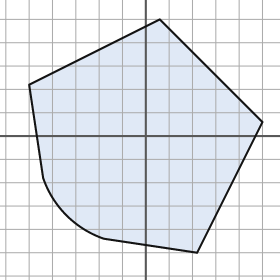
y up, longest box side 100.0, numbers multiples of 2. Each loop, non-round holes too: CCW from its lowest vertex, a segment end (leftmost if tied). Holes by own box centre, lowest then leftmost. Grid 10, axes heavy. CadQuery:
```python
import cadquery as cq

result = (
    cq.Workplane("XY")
    .moveTo(22.0, -50.0)
    .lineTo(50.0, 6.0)
    .lineTo(6.0, 50.0)
    .lineTo(-50.0, 22.0)
    .lineTo(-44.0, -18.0)
    .threePointArc((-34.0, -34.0), (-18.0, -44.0))
    .close()
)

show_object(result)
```